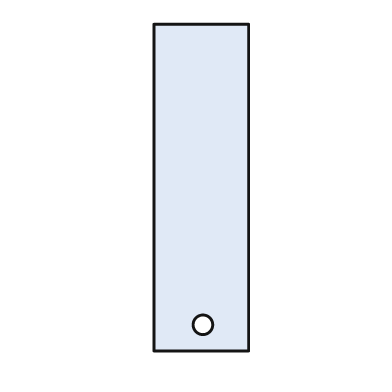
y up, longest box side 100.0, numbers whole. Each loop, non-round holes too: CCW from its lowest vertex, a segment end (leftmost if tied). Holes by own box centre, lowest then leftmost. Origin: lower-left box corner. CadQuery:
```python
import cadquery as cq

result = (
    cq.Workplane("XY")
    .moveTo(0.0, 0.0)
    .lineTo(29.0, 0.0)
    .lineTo(29.0, 100.0)
    .lineTo(0.0, 100.0)
    .close()
    .moveTo(15.0, 8.0)
    .circle(3.0)
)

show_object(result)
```